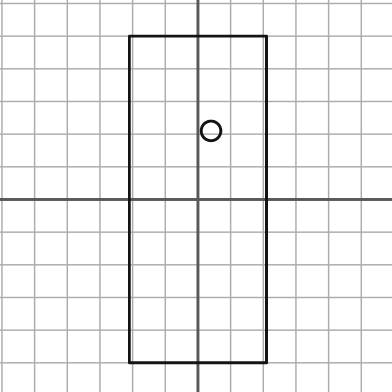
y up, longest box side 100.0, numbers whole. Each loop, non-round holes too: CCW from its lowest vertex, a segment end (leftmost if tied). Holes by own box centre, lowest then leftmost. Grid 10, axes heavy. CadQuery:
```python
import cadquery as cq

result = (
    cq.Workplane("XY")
    .moveTo(-21.0, -50.0)
    .lineTo(21.0, -50.0)
    .lineTo(21.0, 50.0)
    .lineTo(-21.0, 50.0)
    .close()
    .moveTo(4.0, 21.0)
    .circle(3.0)
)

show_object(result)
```